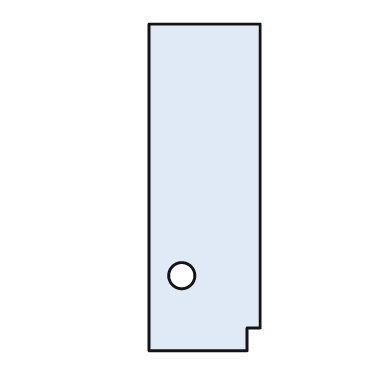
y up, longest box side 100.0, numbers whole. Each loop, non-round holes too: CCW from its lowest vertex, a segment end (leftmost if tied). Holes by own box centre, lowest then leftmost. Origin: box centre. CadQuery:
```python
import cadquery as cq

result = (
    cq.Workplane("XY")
    .moveTo(-17.0, -50.0)
    .lineTo(13.0, -50.0)
    .lineTo(13.0, -43.0)
    .lineTo(17.0, -43.0)
    .lineTo(17.0, 50.0)
    .lineTo(-17.0, 50.0)
    .close()
    .moveTo(-7.0, -27.0)
    .circle(4.0)
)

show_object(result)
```